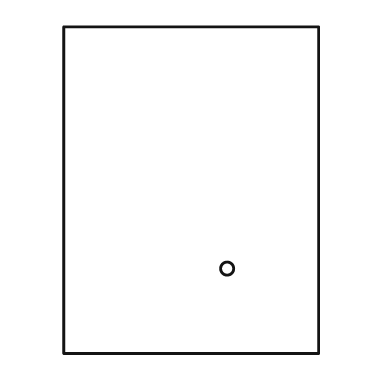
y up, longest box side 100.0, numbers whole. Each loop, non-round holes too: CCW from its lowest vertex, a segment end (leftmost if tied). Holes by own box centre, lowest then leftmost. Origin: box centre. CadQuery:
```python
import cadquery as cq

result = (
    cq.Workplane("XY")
    .moveTo(-39.0, -50.0)
    .lineTo(39.0, -50.0)
    .lineTo(39.0, 50.0)
    .lineTo(-39.0, 50.0)
    .close()
    .moveTo(11.0, -24.0)
    .circle(2.0)
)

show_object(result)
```